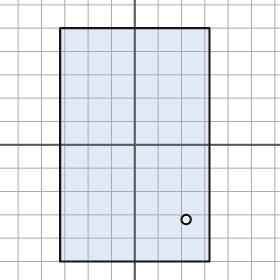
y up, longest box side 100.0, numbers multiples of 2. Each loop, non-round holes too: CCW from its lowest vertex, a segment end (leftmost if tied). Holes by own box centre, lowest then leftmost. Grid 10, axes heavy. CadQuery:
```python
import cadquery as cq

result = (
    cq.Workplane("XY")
    .moveTo(-32.0, -50.0)
    .lineTo(32.0, -50.0)
    .lineTo(32.0, 50.0)
    .lineTo(-32.0, 50.0)
    .close()
    .moveTo(22.0, -32.0)
    .circle(2.0)
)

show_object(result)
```